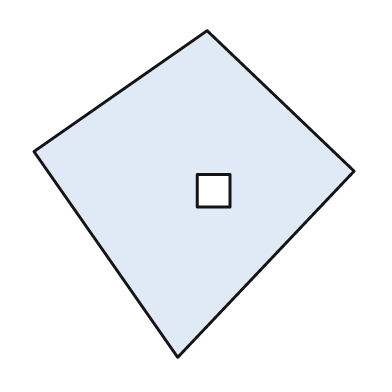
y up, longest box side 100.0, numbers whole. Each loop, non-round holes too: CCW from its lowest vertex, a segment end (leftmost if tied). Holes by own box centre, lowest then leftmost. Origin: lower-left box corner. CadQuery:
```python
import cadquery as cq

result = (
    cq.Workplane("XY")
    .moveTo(44.0, 0.0)
    .lineTo(98.0, 57.0)
    .lineTo(53.0, 100.0)
    .lineTo(0.0, 63.0)
    .close()
    .moveTo(50.0, 46.0)
    .lineTo(60.0, 46.0)
    .lineTo(60.0, 56.0)
    .lineTo(50.0, 56.0)
    .close()
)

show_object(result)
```